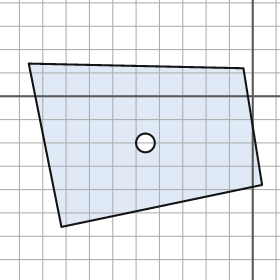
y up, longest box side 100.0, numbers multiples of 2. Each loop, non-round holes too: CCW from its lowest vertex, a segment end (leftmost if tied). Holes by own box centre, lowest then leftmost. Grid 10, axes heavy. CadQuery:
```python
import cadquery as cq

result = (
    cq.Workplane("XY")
    .moveTo(-82.0, -56.0)
    .lineTo(4.0, -38.0)
    .lineTo(-4.0, 12.0)
    .lineTo(-96.0, 14.0)
    .close()
    .moveTo(-46.0, -20.0)
    .circle(4.0)
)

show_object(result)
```